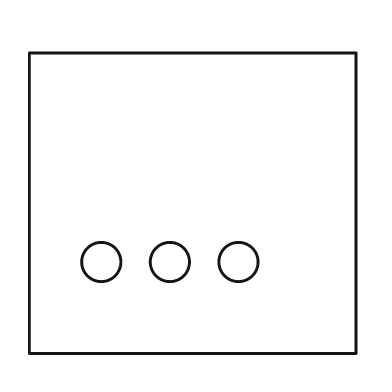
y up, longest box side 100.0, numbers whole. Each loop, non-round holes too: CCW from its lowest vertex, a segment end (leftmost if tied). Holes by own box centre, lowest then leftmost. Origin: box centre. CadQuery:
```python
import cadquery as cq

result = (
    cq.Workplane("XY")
    .moveTo(-50.0, -46.0)
    .lineTo(50.0, -46.0)
    .lineTo(50.0, 46.0)
    .lineTo(-50.0, 46.0)
    .close()
    .moveTo(-28.0, -18.0)
    .circle(6.0)
    .moveTo(-7.0, -18.0)
    .circle(6.0)
    .moveTo(14.0, -18.0)
    .circle(6.0)
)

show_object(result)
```